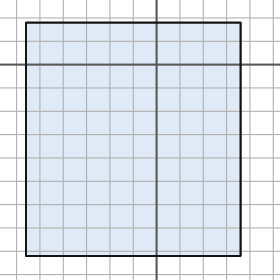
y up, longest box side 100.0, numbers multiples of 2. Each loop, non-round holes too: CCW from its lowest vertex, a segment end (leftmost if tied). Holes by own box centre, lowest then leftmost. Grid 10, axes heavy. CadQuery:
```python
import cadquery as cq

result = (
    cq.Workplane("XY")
    .moveTo(-56.0, -82.0)
    .lineTo(36.0, -82.0)
    .lineTo(36.0, 18.0)
    .lineTo(-56.0, 18.0)
    .close()
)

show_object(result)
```